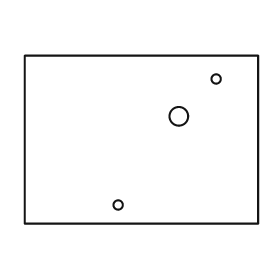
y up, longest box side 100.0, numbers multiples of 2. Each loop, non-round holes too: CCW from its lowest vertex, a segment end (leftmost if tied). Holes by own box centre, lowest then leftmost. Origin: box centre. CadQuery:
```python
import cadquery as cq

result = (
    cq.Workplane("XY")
    .moveTo(-50.0, -36.0)
    .lineTo(50.0, -36.0)
    .lineTo(50.0, 36.0)
    .lineTo(-50.0, 36.0)
    .close()
    .moveTo(-10.0, -28.0)
    .circle(2.0)
    .moveTo(16.0, 10.0)
    .circle(4.0)
    .moveTo(32.0, 26.0)
    .circle(2.0)
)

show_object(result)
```